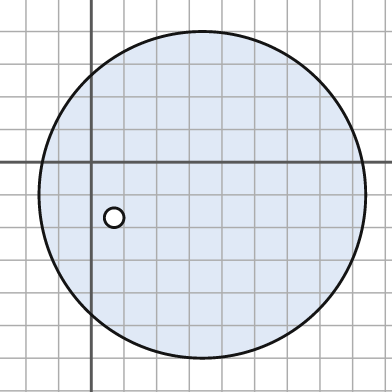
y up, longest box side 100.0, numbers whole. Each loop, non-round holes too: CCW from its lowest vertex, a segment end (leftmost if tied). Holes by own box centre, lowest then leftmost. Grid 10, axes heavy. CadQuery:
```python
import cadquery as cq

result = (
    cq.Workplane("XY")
    .moveTo(34.0, -10.0)
    .circle(50.0)
    .moveTo(7.0, -17.0)
    .circle(3.0)
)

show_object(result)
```